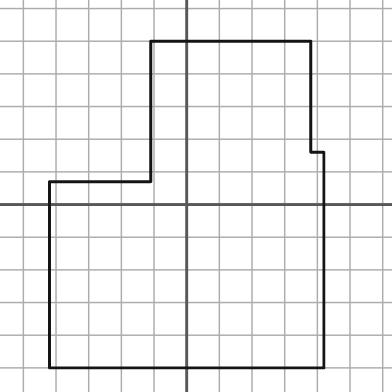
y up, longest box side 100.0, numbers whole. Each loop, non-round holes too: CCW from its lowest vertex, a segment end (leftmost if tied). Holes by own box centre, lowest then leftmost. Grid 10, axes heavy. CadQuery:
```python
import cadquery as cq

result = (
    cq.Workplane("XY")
    .moveTo(-42.0, -50.0)
    .lineTo(42.0, -50.0)
    .lineTo(42.0, 16.0)
    .lineTo(38.0, 16.0)
    .lineTo(38.0, 50.0)
    .lineTo(-11.0, 50.0)
    .lineTo(-11.0, 7.0)
    .lineTo(-42.0, 7.0)
    .close()
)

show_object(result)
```